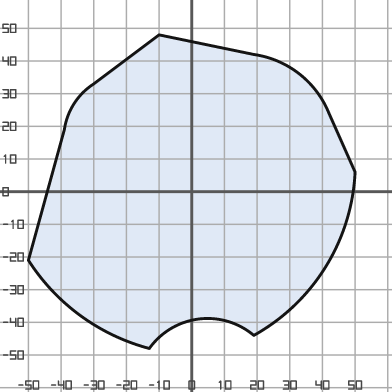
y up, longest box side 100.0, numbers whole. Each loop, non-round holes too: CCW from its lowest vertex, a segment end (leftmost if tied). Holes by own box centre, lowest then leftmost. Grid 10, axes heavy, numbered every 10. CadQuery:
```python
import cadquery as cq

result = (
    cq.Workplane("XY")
    .moveTo(-13.0, -48.0)
    .threePointArc((2.0, -39.0), (19.0, -44.0))
    .threePointArc((41.0, -23.0), (50.0, 6.0))
    .lineTo(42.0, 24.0)
    .threePointArc((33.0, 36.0), (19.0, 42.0))
    .lineTo(-10.0, 48.0)
    .lineTo(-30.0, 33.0)
    .threePointArc((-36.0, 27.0), (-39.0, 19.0))
    .lineTo(-50.0, -21.0)
    .threePointArc((-34.0, -38.0), (-13.0, -48.0))
    .close()
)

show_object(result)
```